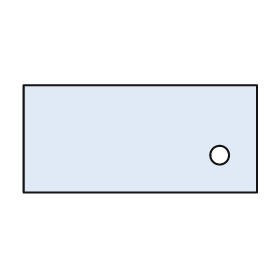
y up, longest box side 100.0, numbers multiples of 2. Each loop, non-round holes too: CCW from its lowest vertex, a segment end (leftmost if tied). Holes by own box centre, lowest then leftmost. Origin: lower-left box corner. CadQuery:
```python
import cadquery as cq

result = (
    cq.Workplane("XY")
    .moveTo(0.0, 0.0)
    .lineTo(100.0, 0.0)
    .lineTo(100.0, 46.0)
    .lineTo(0.0, 46.0)
    .close()
    .moveTo(84.0, 16.0)
    .circle(4.0)
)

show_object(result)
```